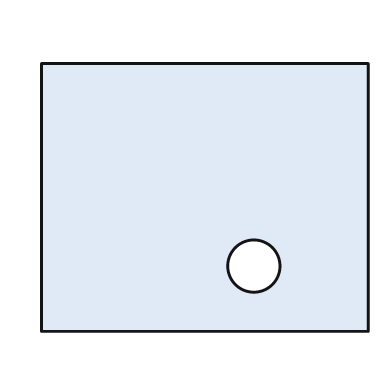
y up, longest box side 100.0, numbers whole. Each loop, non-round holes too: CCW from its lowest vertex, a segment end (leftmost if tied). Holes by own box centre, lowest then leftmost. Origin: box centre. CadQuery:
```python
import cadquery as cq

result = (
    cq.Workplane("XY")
    .moveTo(-50.0, -41.0)
    .lineTo(50.0, -41.0)
    .lineTo(50.0, 41.0)
    .lineTo(-50.0, 41.0)
    .close()
    .moveTo(15.0, -21.0)
    .circle(8.0)
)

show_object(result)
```